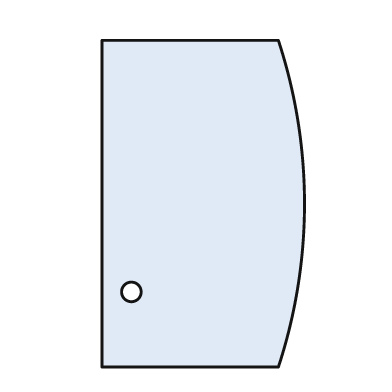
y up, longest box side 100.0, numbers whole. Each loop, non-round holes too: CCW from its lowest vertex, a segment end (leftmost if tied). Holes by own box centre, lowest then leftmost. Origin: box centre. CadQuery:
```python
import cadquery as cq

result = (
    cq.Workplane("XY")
    .moveTo(-31.0, -50.0)
    .lineTo(23.0, -50.0)
    .threePointArc((31.0, 0.0), (23.0, 50.0))
    .lineTo(-31.0, 50.0)
    .close()
    .moveTo(-22.0, -27.0)
    .circle(3.0)
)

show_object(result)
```